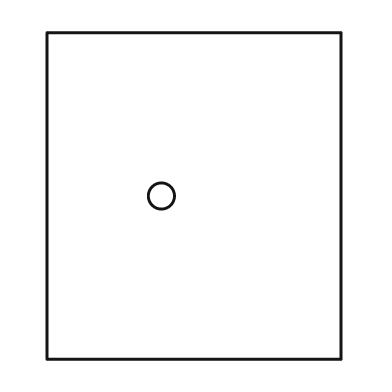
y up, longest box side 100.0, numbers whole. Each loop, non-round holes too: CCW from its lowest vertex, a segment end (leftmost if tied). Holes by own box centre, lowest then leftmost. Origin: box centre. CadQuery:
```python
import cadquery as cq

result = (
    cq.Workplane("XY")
    .moveTo(-45.0, -50.0)
    .lineTo(45.0, -50.0)
    .lineTo(45.0, 50.0)
    .lineTo(-45.0, 50.0)
    .close()
    .moveTo(-10.0, 0.0)
    .circle(4.0)
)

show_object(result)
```